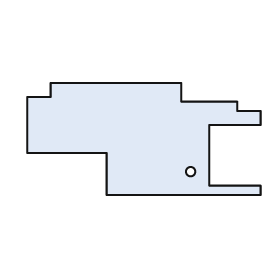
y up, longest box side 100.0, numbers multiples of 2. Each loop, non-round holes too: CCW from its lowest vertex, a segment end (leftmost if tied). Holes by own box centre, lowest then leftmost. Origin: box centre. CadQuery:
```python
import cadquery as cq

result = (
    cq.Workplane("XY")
    .moveTo(-16.0, -24.0)
    .lineTo(50.0, -24.0)
    .lineTo(50.0, -20.0)
    .lineTo(28.0, -20.0)
    .lineTo(28.0, 6.0)
    .lineTo(50.0, 6.0)
    .lineTo(50.0, 12.0)
    .lineTo(40.0, 12.0)
    .lineTo(40.0, 16.0)
    .lineTo(16.0, 16.0)
    .lineTo(16.0, 24.0)
    .lineTo(-40.0, 24.0)
    .lineTo(-40.0, 18.0)
    .lineTo(-50.0, 18.0)
    .lineTo(-50.0, -6.0)
    .lineTo(-16.0, -6.0)
    .close()
    .moveTo(20.0, -14.0)
    .circle(2.0)
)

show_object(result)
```